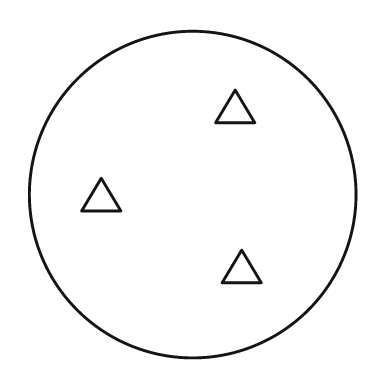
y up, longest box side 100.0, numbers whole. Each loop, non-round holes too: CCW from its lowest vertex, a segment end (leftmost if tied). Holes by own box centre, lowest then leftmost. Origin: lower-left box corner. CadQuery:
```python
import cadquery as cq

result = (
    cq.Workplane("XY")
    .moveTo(50.0, 50.0)
    .circle(50.0)
    .moveTo(59.0, 23.0)
    .lineTo(71.0, 23.0)
    .lineTo(65.0, 33.0)
    .close()
    .moveTo(16.0, 45.0)
    .lineTo(28.0, 45.0)
    .lineTo(22.0, 55.0)
    .close()
    .moveTo(57.0, 72.0)
    .lineTo(69.0, 72.0)
    .lineTo(63.0, 82.0)
    .close()
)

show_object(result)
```